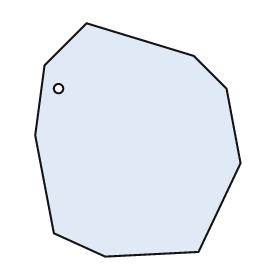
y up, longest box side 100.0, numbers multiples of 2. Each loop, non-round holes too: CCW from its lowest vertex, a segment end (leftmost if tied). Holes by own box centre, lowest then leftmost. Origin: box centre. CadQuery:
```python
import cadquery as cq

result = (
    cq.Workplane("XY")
    .moveTo(-14.0, -50.0)
    .lineTo(26.0, -48.0)
    .lineTo(44.0, -10.0)
    .lineTo(38.0, 22.0)
    .lineTo(24.0, 36.0)
    .lineTo(-22.0, 50.0)
    .lineTo(-40.0, 32.0)
    .lineTo(-44.0, 2.0)
    .lineTo(-36.0, -40.0)
    .close()
    .moveTo(-34.0, 22.0)
    .circle(2.0)
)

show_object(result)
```